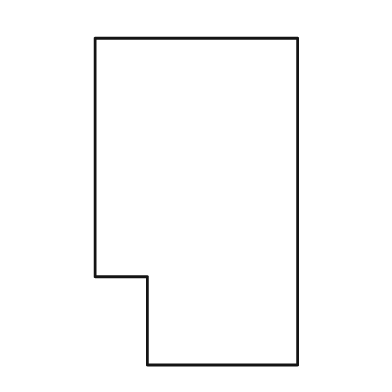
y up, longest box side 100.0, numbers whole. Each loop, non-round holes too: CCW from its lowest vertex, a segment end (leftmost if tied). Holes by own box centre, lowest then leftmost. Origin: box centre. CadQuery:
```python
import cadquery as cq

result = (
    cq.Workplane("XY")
    .moveTo(-15.0, -50.0)
    .lineTo(31.0, -50.0)
    .lineTo(31.0, 50.0)
    .lineTo(-31.0, 50.0)
    .lineTo(-31.0, -23.0)
    .lineTo(-15.0, -23.0)
    .close()
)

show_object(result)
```